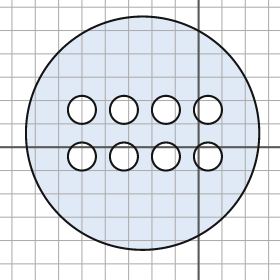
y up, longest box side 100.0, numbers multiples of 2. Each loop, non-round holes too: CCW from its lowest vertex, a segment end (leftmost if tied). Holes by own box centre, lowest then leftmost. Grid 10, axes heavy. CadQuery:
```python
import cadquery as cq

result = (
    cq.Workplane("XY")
    .moveTo(-24.0, 6.0)
    .circle(50.0)
    .moveTo(-50.0, -4.0)
    .circle(6.0)
    .moveTo(-32.0, -4.0)
    .circle(6.0)
    .moveTo(-14.0, -4.0)
    .circle(6.0)
    .moveTo(4.0, -4.0)
    .circle(6.0)
    .moveTo(-50.0, 16.0)
    .circle(6.0)
    .moveTo(-32.0, 16.0)
    .circle(6.0)
    .moveTo(-14.0, 16.0)
    .circle(6.0)
    .moveTo(4.0, 16.0)
    .circle(6.0)
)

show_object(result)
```